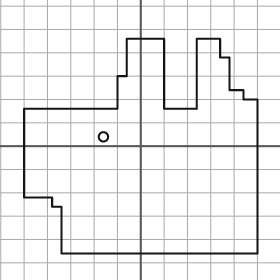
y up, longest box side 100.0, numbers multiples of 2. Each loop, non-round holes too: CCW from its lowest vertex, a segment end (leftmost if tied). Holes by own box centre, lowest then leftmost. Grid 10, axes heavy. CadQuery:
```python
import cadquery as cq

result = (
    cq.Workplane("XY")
    .moveTo(-34.0, -46.0)
    .lineTo(50.0, -46.0)
    .lineTo(50.0, 20.0)
    .lineTo(44.0, 20.0)
    .lineTo(44.0, 24.0)
    .lineTo(38.0, 24.0)
    .lineTo(38.0, 38.0)
    .lineTo(34.0, 38.0)
    .lineTo(34.0, 46.0)
    .lineTo(24.0, 46.0)
    .lineTo(24.0, 16.0)
    .lineTo(10.0, 16.0)
    .lineTo(10.0, 46.0)
    .lineTo(-6.0, 46.0)
    .lineTo(-6.0, 30.0)
    .lineTo(-10.0, 30.0)
    .lineTo(-10.0, 16.0)
    .lineTo(-50.0, 16.0)
    .lineTo(-50.0, -22.0)
    .lineTo(-38.0, -22.0)
    .lineTo(-38.0, -26.0)
    .lineTo(-34.0, -26.0)
    .close()
    .moveTo(-16.0, 4.0)
    .circle(2.0)
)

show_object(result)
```